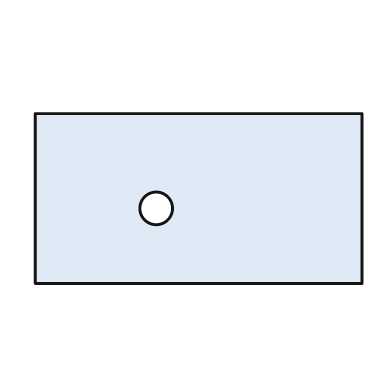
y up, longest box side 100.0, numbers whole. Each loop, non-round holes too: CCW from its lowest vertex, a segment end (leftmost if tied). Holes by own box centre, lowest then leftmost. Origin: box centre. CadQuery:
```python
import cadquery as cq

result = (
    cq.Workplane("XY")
    .moveTo(-50.0, -26.0)
    .lineTo(50.0, -26.0)
    .lineTo(50.0, 26.0)
    .lineTo(-50.0, 26.0)
    .close()
    .moveTo(-13.0, -3.0)
    .circle(5.0)
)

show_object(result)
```